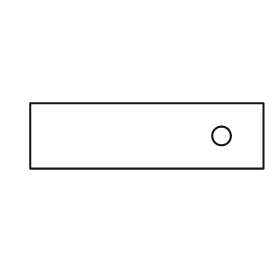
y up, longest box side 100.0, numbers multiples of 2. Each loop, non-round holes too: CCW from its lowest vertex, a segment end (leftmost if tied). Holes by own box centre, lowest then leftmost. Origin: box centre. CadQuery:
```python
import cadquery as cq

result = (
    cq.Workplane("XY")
    .moveTo(-50.0, -14.0)
    .lineTo(50.0, -14.0)
    .lineTo(50.0, 14.0)
    .lineTo(-50.0, 14.0)
    .close()
    .moveTo(32.0, 0.0)
    .circle(4.0)
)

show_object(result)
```